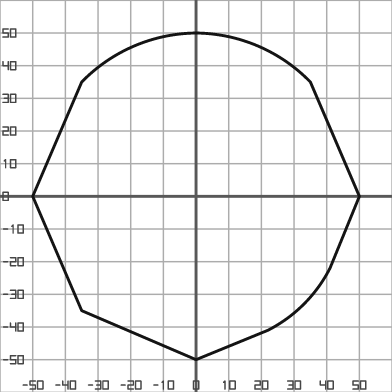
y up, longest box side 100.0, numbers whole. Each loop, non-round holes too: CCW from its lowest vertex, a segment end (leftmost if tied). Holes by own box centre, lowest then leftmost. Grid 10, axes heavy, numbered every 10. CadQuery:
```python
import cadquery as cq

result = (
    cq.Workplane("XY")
    .moveTo(0.0, -50.0)
    .lineTo(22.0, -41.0)
    .threePointArc((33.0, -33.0), (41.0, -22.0))
    .lineTo(50.0, 0.0)
    .lineTo(35.0, 35.0)
    .threePointArc((19.0, 46.0), (0.0, 50.0))
    .threePointArc((-19.0, 46.0), (-35.0, 35.0))
    .lineTo(-50.0, 0.0)
    .lineTo(-35.0, -35.0)
    .close()
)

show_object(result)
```